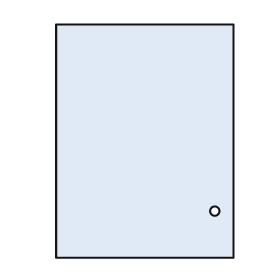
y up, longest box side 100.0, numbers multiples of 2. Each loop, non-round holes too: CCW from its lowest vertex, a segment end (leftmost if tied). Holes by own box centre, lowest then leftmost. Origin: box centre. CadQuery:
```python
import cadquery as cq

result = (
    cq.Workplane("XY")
    .moveTo(-38.0, -50.0)
    .lineTo(38.0, -50.0)
    .lineTo(38.0, 50.0)
    .lineTo(-38.0, 50.0)
    .close()
    .moveTo(30.0, -30.0)
    .circle(2.0)
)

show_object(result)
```